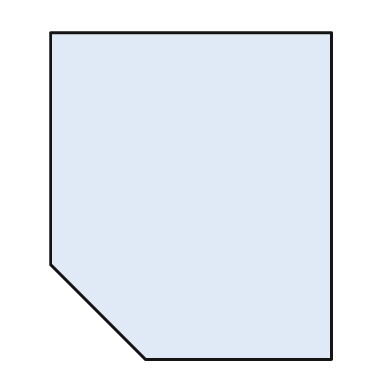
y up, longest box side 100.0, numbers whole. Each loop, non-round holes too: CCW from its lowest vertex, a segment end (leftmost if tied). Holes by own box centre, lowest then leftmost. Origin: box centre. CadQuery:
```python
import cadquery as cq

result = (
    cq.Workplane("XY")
    .moveTo(-14.0, -50.0)
    .lineTo(43.0, -50.0)
    .lineTo(43.0, 50.0)
    .lineTo(-43.0, 50.0)
    .lineTo(-43.0, -21.0)
    .close()
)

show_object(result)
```